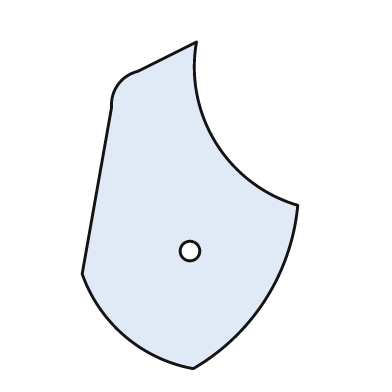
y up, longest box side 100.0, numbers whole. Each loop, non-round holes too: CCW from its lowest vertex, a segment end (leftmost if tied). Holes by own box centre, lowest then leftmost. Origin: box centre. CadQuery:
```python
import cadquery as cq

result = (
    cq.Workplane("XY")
    .moveTo(1.0, -50.0)
    .threePointArc((23.0, -29.0), (33.0, 0.0))
    .threePointArc((8.0, 19.0), (2.0, 50.0))
    .lineTo(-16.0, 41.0)
    .threePointArc((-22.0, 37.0), (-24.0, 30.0))
    .lineTo(-33.0, -21.0)
    .threePointArc((-20.0, -40.0), (1.0, -50.0))
    .close()
    .moveTo(0.0, -14.0)
    .circle(3.0)
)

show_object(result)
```